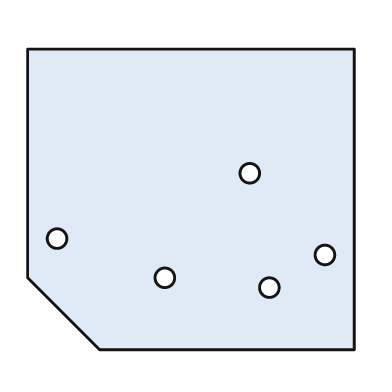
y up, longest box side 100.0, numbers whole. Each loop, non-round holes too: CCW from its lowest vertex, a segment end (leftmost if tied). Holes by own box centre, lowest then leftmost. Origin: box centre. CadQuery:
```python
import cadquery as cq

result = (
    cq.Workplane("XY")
    .moveTo(-28.0, -46.0)
    .lineTo(50.0, -46.0)
    .lineTo(50.0, 46.0)
    .lineTo(-50.0, 46.0)
    .lineTo(-50.0, -24.0)
    .close()
    .moveTo(24.0, -27.0)
    .circle(3.0)
    .moveTo(-8.0, -24.0)
    .circle(3.0)
    .moveTo(41.0, -17.0)
    .circle(3.0)
    .moveTo(-41.0, -12.0)
    .circle(3.0)
    .moveTo(18.0, 8.0)
    .circle(3.0)
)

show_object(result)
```